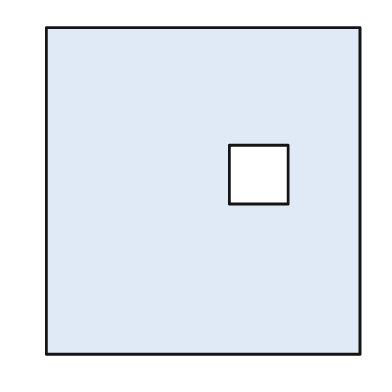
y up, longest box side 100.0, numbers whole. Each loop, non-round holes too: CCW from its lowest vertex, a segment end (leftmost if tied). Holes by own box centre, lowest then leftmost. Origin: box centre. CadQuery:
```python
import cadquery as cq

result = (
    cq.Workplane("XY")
    .moveTo(-48.0, -50.0)
    .lineTo(48.0, -50.0)
    .lineTo(48.0, 50.0)
    .lineTo(-48.0, 50.0)
    .close()
    .moveTo(8.0, -4.0)
    .lineTo(26.0, -4.0)
    .lineTo(26.0, 14.0)
    .lineTo(8.0, 14.0)
    .close()
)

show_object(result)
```